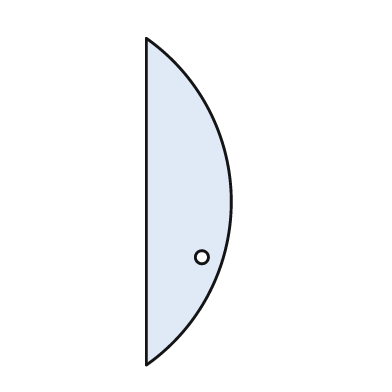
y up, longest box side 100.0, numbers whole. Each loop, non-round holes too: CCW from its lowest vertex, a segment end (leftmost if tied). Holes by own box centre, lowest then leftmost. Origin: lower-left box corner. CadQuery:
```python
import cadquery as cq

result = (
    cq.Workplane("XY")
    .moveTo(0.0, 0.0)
    .threePointArc((26.0, 50.0), (0.0, 100.0))
    .close()
    .moveTo(17.0, 33.0)
    .circle(2.0)
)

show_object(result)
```